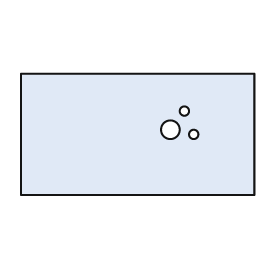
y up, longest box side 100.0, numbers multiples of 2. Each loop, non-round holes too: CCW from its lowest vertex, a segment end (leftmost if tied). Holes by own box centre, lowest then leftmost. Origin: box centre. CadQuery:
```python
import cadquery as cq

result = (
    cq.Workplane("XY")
    .moveTo(-50.0, -26.0)
    .lineTo(50.0, -26.0)
    .lineTo(50.0, 26.0)
    .lineTo(-50.0, 26.0)
    .close()
    .moveTo(24.0, 0.0)
    .circle(2.0)
    .moveTo(14.0, 2.0)
    .circle(4.0)
    .moveTo(20.0, 10.0)
    .circle(2.0)
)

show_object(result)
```